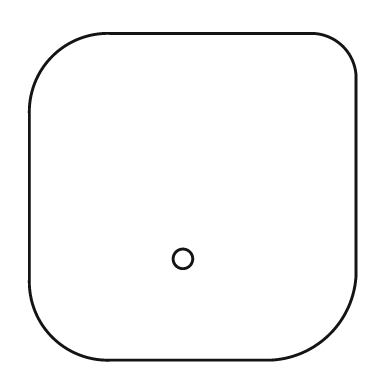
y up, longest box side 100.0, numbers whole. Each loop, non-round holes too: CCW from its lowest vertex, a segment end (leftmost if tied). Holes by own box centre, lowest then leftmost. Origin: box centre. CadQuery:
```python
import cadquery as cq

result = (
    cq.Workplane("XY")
    .moveTo(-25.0, -50.0)
    .lineTo(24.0, -50.0)
    .threePointArc((42.0, -42.0), (50.0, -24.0))
    .lineTo(50.0, 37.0)
    .threePointArc((46.0, 46.0), (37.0, 50.0))
    .lineTo(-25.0, 50.0)
    .threePointArc((-43.0, 43.0), (-50.0, 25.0))
    .lineTo(-50.0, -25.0)
    .threePointArc((-43.0, -43.0), (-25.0, -50.0))
    .close()
    .moveTo(-3.0, -19.0)
    .circle(3.0)
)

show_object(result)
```